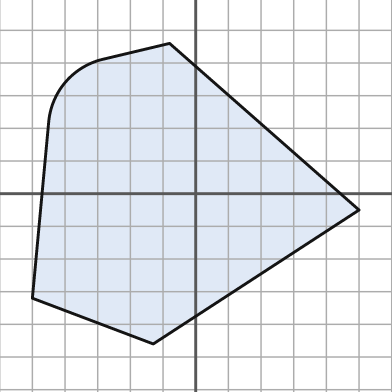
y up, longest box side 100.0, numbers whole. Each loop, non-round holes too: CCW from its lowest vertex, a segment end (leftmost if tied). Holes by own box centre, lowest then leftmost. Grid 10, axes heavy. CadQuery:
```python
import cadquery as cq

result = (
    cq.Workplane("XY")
    .moveTo(-13.0, -46.0)
    .lineTo(50.0, -5.0)
    .lineTo(-8.0, 46.0)
    .lineTo(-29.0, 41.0)
    .threePointArc((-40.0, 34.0), (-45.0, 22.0))
    .lineTo(-50.0, -32.0)
    .close()
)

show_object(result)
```